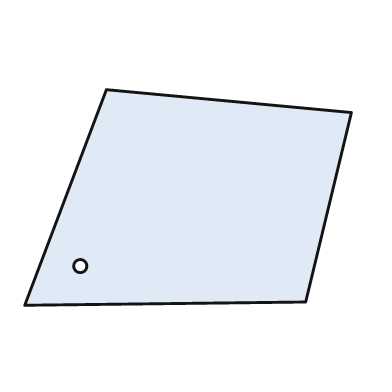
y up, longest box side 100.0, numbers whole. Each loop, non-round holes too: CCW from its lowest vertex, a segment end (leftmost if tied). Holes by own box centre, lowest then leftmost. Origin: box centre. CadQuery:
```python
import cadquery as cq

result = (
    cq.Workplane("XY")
    .moveTo(-50.0, -33.0)
    .lineTo(36.0, -32.0)
    .lineTo(50.0, 26.0)
    .lineTo(-25.0, 33.0)
    .close()
    .moveTo(-33.0, -21.0)
    .circle(2.0)
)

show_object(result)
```